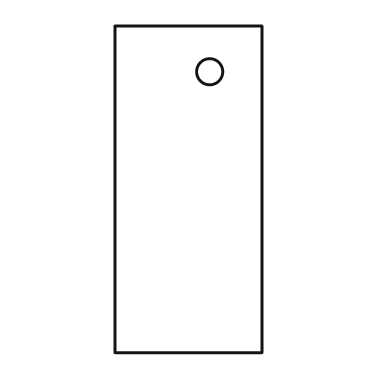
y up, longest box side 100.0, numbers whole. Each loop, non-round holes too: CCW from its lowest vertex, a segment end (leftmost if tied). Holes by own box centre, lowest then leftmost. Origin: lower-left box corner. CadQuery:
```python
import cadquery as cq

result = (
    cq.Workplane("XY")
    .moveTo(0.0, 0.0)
    .lineTo(45.0, 0.0)
    .lineTo(45.0, 100.0)
    .lineTo(0.0, 100.0)
    .close()
    .moveTo(29.0, 86.0)
    .circle(4.0)
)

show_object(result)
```